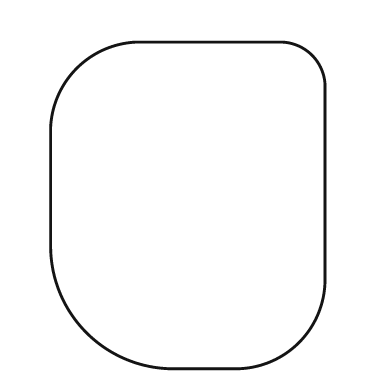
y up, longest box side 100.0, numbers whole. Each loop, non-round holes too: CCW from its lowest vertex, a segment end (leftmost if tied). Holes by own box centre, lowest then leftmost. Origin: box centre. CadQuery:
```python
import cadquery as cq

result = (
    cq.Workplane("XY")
    .moveTo(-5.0, -50.0)
    .lineTo(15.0, -50.0)
    .threePointArc((34.0, -42.0), (42.0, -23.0))
    .lineTo(42.0, 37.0)
    .threePointArc((38.0, 46.0), (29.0, 50.0))
    .lineTo(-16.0, 50.0)
    .threePointArc((-34.0, 42.0), (-42.0, 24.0))
    .lineTo(-42.0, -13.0)
    .threePointArc((-31.0, -39.0), (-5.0, -50.0))
    .close()
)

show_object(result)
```